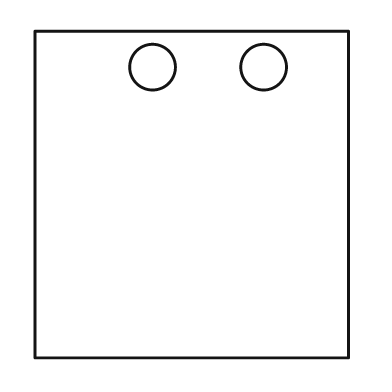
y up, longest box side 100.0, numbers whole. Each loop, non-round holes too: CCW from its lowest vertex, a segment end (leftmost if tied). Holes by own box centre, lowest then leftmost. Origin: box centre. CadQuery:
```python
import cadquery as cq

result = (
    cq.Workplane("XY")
    .moveTo(-48.0, -50.0)
    .lineTo(48.0, -50.0)
    .lineTo(48.0, 50.0)
    .lineTo(-48.0, 50.0)
    .close()
    .moveTo(-12.0, 39.0)
    .circle(7.0)
    .moveTo(22.0, 39.0)
    .circle(7.0)
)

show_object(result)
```